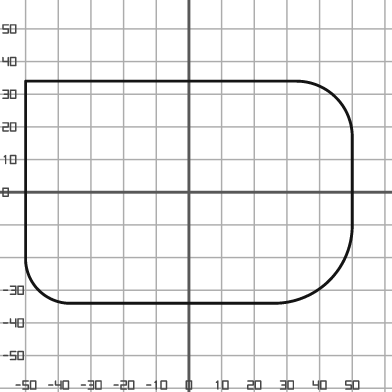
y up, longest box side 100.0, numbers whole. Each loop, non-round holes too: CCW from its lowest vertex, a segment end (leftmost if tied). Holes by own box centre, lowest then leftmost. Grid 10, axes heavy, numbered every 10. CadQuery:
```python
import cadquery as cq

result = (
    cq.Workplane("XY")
    .moveTo(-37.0, -34.0)
    .lineTo(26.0, -34.0)
    .threePointArc((43.0, -27.0), (50.0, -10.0))
    .lineTo(50.0, 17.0)
    .threePointArc((45.0, 29.0), (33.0, 34.0))
    .lineTo(-50.0, 34.0)
    .lineTo(-50.0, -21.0)
    .threePointArc((-46.0, -30.0), (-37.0, -34.0))
    .close()
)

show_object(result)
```